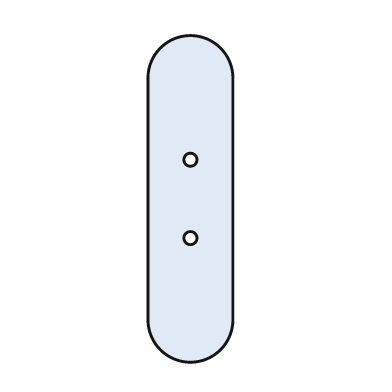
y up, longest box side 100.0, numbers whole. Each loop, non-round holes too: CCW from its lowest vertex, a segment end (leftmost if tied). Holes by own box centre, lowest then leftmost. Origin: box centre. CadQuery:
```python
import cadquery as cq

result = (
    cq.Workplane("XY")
    .moveTo(-13.0, -37.0)
    .threePointArc((0.0, -50.0), (13.0, -37.0))
    .lineTo(13.0, 37.0)
    .threePointArc((0.0, 50.0), (-13.0, 37.0))
    .close()
    .moveTo(0.0, -12.0)
    .circle(2.0)
    .moveTo(0.0, 12.0)
    .circle(2.0)
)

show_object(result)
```